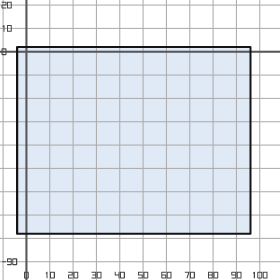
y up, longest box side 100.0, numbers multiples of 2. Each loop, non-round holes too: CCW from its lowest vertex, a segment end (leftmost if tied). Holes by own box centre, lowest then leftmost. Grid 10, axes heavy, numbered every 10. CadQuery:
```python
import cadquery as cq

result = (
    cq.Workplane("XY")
    .moveTo(-4.0, -78.0)
    .lineTo(96.0, -78.0)
    .lineTo(96.0, 2.0)
    .lineTo(-4.0, 2.0)
    .close()
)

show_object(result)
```